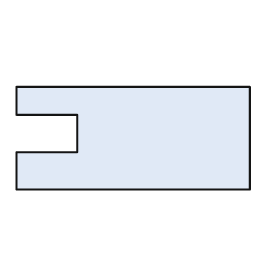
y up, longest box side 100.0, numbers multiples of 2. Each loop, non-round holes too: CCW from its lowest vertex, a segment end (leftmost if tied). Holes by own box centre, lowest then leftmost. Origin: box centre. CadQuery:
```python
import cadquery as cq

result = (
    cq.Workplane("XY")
    .moveTo(-50.0, -22.0)
    .lineTo(50.0, -22.0)
    .lineTo(50.0, 22.0)
    .lineTo(-50.0, 22.0)
    .lineTo(-50.0, 10.0)
    .lineTo(-24.0, 10.0)
    .lineTo(-24.0, -6.0)
    .lineTo(-50.0, -6.0)
    .close()
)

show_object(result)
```